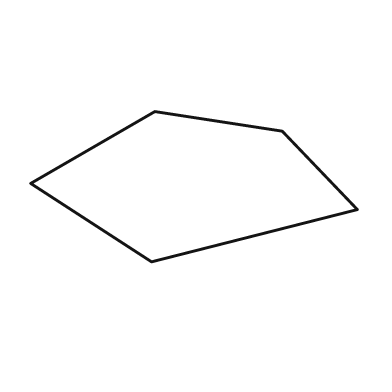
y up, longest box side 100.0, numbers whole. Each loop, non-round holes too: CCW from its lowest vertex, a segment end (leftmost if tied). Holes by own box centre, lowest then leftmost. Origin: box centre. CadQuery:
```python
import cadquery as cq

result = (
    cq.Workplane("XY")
    .moveTo(-13.0, -23.0)
    .lineTo(50.0, -7.0)
    .lineTo(27.0, 17.0)
    .lineTo(-12.0, 23.0)
    .lineTo(-50.0, 1.0)
    .close()
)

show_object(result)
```